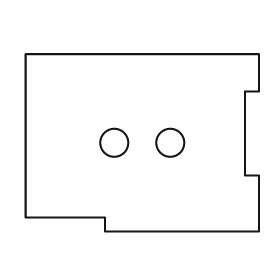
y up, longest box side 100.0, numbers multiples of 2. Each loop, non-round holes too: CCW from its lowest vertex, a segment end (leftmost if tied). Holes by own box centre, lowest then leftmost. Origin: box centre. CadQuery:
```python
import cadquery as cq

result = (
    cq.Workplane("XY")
    .moveTo(-16.0, -38.0)
    .lineTo(50.0, -38.0)
    .lineTo(50.0, -14.0)
    .lineTo(44.0, -14.0)
    .lineTo(44.0, 22.0)
    .lineTo(50.0, 22.0)
    .lineTo(50.0, 38.0)
    .lineTo(-50.0, 38.0)
    .lineTo(-50.0, -32.0)
    .lineTo(-16.0, -32.0)
    .close()
    .moveTo(-12.0, 0.0)
    .circle(6.0)
    .moveTo(12.0, 0.0)
    .circle(6.0)
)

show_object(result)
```